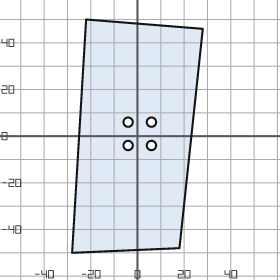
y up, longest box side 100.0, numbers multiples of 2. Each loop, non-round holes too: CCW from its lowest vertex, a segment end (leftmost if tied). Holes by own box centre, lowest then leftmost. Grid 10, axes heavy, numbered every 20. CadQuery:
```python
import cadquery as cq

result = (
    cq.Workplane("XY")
    .moveTo(-28.0, -50.0)
    .lineTo(18.0, -48.0)
    .lineTo(28.0, 46.0)
    .lineTo(-22.0, 50.0)
    .close()
    .moveTo(-4.0, -4.0)
    .circle(2.0)
    .moveTo(6.0, -4.0)
    .circle(2.0)
    .moveTo(-4.0, 6.0)
    .circle(2.0)
    .moveTo(6.0, 6.0)
    .circle(2.0)
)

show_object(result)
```